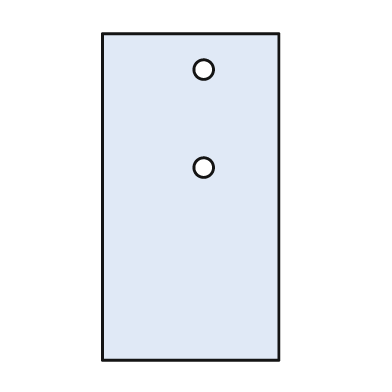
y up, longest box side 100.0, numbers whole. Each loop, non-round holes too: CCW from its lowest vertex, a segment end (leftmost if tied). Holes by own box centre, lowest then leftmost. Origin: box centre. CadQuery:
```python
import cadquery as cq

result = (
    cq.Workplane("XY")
    .moveTo(-27.0, -50.0)
    .lineTo(27.0, -50.0)
    .lineTo(27.0, 50.0)
    .lineTo(-27.0, 50.0)
    .close()
    .moveTo(4.0, 9.0)
    .circle(3.0)
    .moveTo(4.0, 39.0)
    .circle(3.0)
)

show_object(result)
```